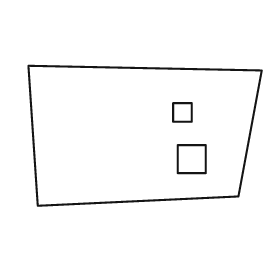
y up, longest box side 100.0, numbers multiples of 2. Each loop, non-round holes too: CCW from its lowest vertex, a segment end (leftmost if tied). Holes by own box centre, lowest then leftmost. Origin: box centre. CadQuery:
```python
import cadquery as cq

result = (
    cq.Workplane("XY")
    .moveTo(-46.0, -30.0)
    .lineTo(40.0, -26.0)
    .lineTo(50.0, 28.0)
    .lineTo(-50.0, 30.0)
    .close()
    .moveTo(14.0, -16.0)
    .lineTo(26.0, -16.0)
    .lineTo(26.0, -4.0)
    .lineTo(14.0, -4.0)
    .close()
    .moveTo(12.0, 6.0)
    .lineTo(20.0, 6.0)
    .lineTo(20.0, 14.0)
    .lineTo(12.0, 14.0)
    .close()
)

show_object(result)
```